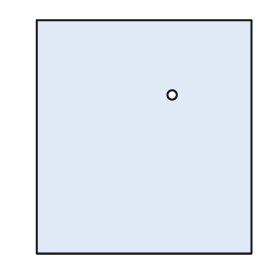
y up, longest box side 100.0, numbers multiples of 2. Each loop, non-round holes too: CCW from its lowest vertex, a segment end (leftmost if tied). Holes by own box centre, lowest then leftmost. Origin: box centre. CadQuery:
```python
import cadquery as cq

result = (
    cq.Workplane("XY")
    .moveTo(-46.0, -50.0)
    .lineTo(46.0, -50.0)
    .lineTo(46.0, 50.0)
    .lineTo(-46.0, 50.0)
    .close()
    .moveTo(12.0, 18.0)
    .circle(2.0)
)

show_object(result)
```